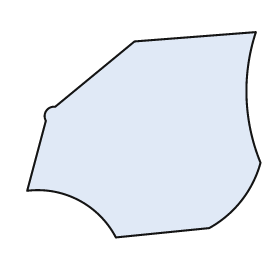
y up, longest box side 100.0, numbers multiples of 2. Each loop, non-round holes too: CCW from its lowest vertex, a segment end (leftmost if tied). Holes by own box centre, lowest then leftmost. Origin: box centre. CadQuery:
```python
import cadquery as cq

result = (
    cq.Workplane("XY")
    .moveTo(-12.0, -44.0)
    .lineTo(28.0, -40.0)
    .threePointArc((42.0, -28.0), (50.0, -12.0))
    .threePointArc((44.0, 16.0), (48.0, 44.0))
    .lineTo(-4.0, 40.0)
    .lineTo(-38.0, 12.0)
    .threePointArc((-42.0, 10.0), (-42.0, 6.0))
    .lineTo(-50.0, -24.0)
    .threePointArc((-28.0, -28.0), (-12.0, -44.0))
    .close()
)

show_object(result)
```